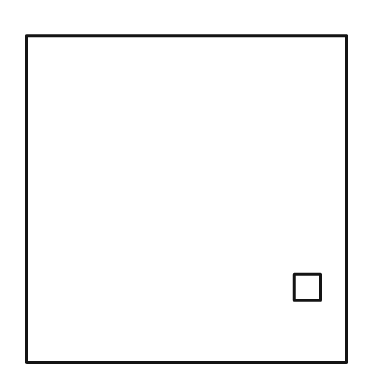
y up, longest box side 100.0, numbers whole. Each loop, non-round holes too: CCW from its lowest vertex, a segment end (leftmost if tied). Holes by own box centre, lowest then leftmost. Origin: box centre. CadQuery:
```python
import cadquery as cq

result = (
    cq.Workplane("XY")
    .moveTo(-49.0, -50.0)
    .lineTo(49.0, -50.0)
    .lineTo(49.0, 50.0)
    .lineTo(-49.0, 50.0)
    .close()
    .moveTo(33.0, -31.0)
    .lineTo(41.0, -31.0)
    .lineTo(41.0, -23.0)
    .lineTo(33.0, -23.0)
    .close()
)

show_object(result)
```